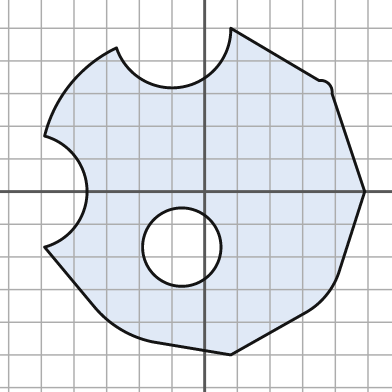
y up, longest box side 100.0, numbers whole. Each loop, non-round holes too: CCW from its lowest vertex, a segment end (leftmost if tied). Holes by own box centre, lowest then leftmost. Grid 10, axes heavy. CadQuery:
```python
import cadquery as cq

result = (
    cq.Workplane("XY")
    .moveTo(8.0, -50.0)
    .lineTo(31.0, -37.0)
    .threePointArc((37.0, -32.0), (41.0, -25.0))
    .lineTo(49.0, 0.0)
    .lineTo(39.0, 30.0)
    .threePointArc((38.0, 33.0), (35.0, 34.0))
    .lineTo(8.0, 50.0)
    .threePointArc((-7.0, 32.0), (-27.0, 44.0))
    .threePointArc((-41.0, 33.0), (-49.0, 17.0))
    .threePointArc((-36.0, 0.0), (-49.0, -17.0))
    .lineTo(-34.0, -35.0)
    .threePointArc((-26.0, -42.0), (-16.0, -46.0))
    .close()
    .moveTo(-7.0, -17.0)
    .circle(12.0)
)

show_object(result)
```